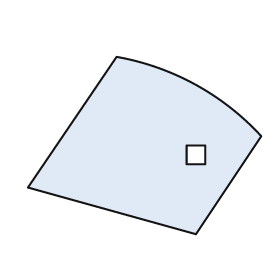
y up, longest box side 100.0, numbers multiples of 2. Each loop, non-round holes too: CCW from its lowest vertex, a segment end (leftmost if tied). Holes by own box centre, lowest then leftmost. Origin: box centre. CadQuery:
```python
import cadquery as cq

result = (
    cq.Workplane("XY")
    .moveTo(22.0, -38.0)
    .lineTo(50.0, 4.0)
    .threePointArc((22.0, 26.0), (-12.0, 38.0))
    .lineTo(-50.0, -18.0)
    .close()
    .moveTo(18.0, -8.0)
    .lineTo(26.0, -8.0)
    .lineTo(26.0, 0.0)
    .lineTo(18.0, 0.0)
    .close()
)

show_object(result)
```